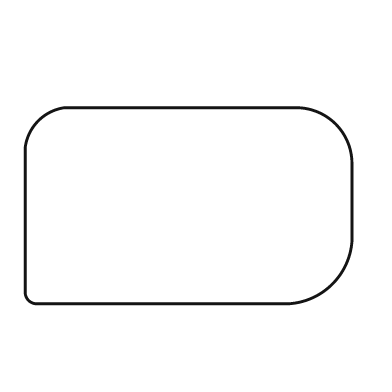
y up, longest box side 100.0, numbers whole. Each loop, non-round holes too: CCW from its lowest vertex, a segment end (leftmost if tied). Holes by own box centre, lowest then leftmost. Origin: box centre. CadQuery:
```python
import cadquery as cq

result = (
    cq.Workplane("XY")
    .moveTo(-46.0, -30.0)
    .lineTo(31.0, -30.0)
    .threePointArc((44.0, -24.0), (50.0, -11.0))
    .lineTo(50.0, 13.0)
    .threePointArc((45.0, 25.0), (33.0, 30.0))
    .lineTo(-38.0, 30.0)
    .threePointArc((-46.0, 26.0), (-50.0, 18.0))
    .lineTo(-50.0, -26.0)
    .threePointArc((-49.0, -29.0), (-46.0, -30.0))
    .close()
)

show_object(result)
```